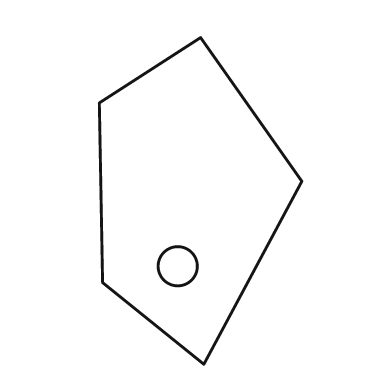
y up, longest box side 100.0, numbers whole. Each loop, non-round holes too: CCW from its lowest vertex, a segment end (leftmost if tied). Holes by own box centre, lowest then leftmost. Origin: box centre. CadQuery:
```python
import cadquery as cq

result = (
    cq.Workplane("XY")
    .moveTo(1.0, -50.0)
    .lineTo(31.0, 6.0)
    .lineTo(0.0, 50.0)
    .lineTo(-31.0, 30.0)
    .lineTo(-30.0, -25.0)
    .close()
    .moveTo(-7.0, -20.0)
    .circle(6.0)
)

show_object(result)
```